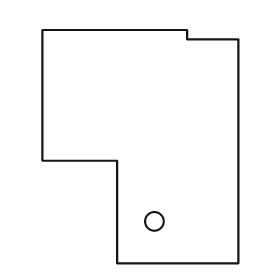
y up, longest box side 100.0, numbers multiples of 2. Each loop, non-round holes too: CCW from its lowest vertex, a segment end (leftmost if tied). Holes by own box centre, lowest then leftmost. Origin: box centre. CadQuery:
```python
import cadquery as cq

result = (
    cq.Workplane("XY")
    .moveTo(-10.0, -50.0)
    .lineTo(42.0, -50.0)
    .lineTo(42.0, 46.0)
    .lineTo(20.0, 46.0)
    .lineTo(20.0, 50.0)
    .lineTo(-42.0, 50.0)
    .lineTo(-42.0, -6.0)
    .lineTo(-10.0, -6.0)
    .close()
    .moveTo(6.0, -32.0)
    .circle(4.0)
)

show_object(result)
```